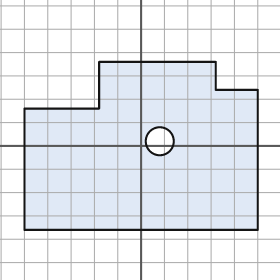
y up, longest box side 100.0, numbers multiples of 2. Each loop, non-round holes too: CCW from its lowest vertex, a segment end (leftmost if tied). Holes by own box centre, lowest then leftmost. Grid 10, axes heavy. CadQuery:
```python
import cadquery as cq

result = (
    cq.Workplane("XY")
    .moveTo(-50.0, -36.0)
    .lineTo(50.0, -36.0)
    .lineTo(50.0, 24.0)
    .lineTo(32.0, 24.0)
    .lineTo(32.0, 36.0)
    .lineTo(-18.0, 36.0)
    .lineTo(-18.0, 16.0)
    .lineTo(-50.0, 16.0)
    .close()
    .moveTo(8.0, 2.0)
    .circle(6.0)
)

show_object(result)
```